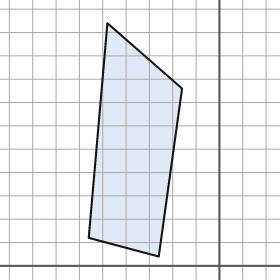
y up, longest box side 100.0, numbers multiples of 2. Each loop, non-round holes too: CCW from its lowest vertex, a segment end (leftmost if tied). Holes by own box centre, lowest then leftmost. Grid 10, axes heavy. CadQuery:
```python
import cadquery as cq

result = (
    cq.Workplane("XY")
    .moveTo(-26.0, 4.0)
    .lineTo(-16.0, 76.0)
    .lineTo(-48.0, 104.0)
    .lineTo(-56.0, 12.0)
    .close()
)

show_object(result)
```